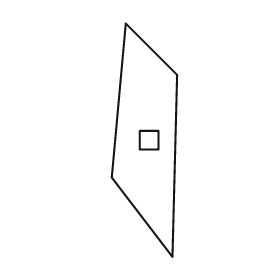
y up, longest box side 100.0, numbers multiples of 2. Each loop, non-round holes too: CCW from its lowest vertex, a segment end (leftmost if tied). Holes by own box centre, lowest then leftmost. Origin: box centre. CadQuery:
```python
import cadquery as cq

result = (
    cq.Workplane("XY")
    .moveTo(12.0, -50.0)
    .lineTo(14.0, 28.0)
    .lineTo(-8.0, 50.0)
    .lineTo(-14.0, -16.0)
    .close()
    .moveTo(-2.0, -4.0)
    .lineTo(6.0, -4.0)
    .lineTo(6.0, 4.0)
    .lineTo(-2.0, 4.0)
    .close()
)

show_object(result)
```